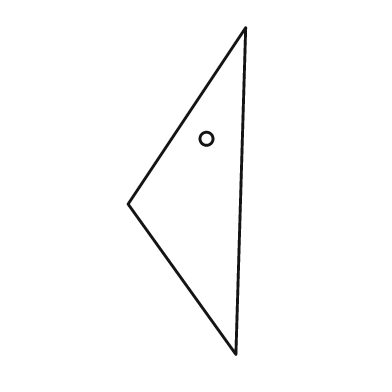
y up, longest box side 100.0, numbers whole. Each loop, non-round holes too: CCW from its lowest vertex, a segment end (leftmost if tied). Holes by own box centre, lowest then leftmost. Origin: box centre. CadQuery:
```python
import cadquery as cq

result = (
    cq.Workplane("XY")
    .moveTo(15.0, -50.0)
    .lineTo(18.0, 50.0)
    .lineTo(-18.0, -4.0)
    .close()
    .moveTo(6.0, 16.0)
    .circle(2.0)
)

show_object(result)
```